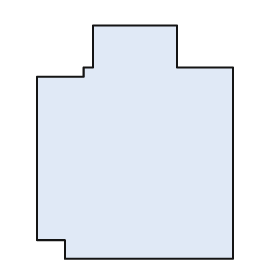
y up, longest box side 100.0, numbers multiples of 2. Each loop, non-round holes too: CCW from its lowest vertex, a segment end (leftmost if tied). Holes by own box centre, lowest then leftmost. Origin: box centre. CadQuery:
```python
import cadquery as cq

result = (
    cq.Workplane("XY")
    .moveTo(-30.0, -50.0)
    .lineTo(42.0, -50.0)
    .lineTo(42.0, 32.0)
    .lineTo(18.0, 32.0)
    .lineTo(18.0, 50.0)
    .lineTo(-18.0, 50.0)
    .lineTo(-18.0, 32.0)
    .lineTo(-22.0, 32.0)
    .lineTo(-22.0, 28.0)
    .lineTo(-42.0, 28.0)
    .lineTo(-42.0, -42.0)
    .lineTo(-30.0, -42.0)
    .close()
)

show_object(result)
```